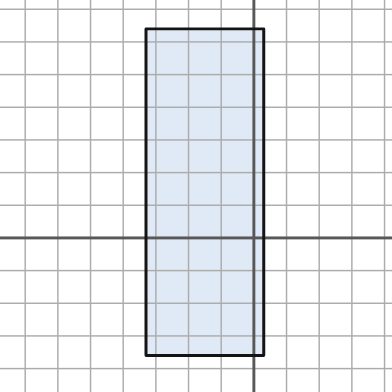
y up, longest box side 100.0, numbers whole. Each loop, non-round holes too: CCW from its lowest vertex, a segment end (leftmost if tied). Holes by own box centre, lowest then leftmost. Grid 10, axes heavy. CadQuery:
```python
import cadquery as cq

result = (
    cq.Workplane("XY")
    .moveTo(-33.0, -36.0)
    .lineTo(3.0, -36.0)
    .lineTo(3.0, 64.0)
    .lineTo(-33.0, 64.0)
    .close()
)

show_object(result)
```